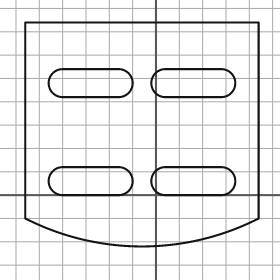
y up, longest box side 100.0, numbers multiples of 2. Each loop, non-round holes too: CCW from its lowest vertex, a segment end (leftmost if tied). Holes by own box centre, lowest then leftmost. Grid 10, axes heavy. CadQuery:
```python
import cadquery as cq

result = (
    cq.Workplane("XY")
    .moveTo(-56.0, -10.0)
    .threePointArc((-6.0, -22.0), (44.0, -10.0))
    .lineTo(44.0, 74.0)
    .lineTo(-56.0, 74.0)
    .close()
    .moveTo(-40.0, 0.0)
    .lineTo(-16.0, 0.0)
    .threePointArc((-10.0, 6.0), (-16.0, 12.0))
    .lineTo(-40.0, 12.0)
    .threePointArc((-46.0, 6.0), (-40.0, 0.0))
    .close()
    .moveTo(4.0, 0.0)
    .lineTo(28.0, 0.0)
    .threePointArc((34.0, 6.0), (28.0, 12.0))
    .lineTo(4.0, 12.0)
    .threePointArc((-2.0, 6.0), (4.0, 0.0))
    .close()
    .moveTo(-40.0, 42.0)
    .lineTo(-16.0, 42.0)
    .threePointArc((-10.0, 48.0), (-16.0, 54.0))
    .lineTo(-40.0, 54.0)
    .threePointArc((-46.0, 48.0), (-40.0, 42.0))
    .close()
    .moveTo(4.0, 42.0)
    .lineTo(28.0, 42.0)
    .threePointArc((34.0, 48.0), (28.0, 54.0))
    .lineTo(4.0, 54.0)
    .threePointArc((-2.0, 48.0), (4.0, 42.0))
    .close()
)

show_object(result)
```